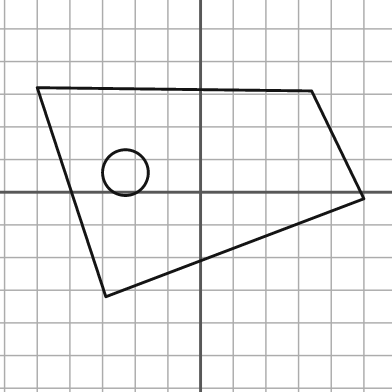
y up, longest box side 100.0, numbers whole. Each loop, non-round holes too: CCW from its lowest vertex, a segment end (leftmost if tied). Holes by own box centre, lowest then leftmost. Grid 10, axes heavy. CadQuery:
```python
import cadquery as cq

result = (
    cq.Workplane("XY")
    .moveTo(-29.0, -32.0)
    .lineTo(50.0, -2.0)
    .lineTo(34.0, 31.0)
    .lineTo(-50.0, 32.0)
    .close()
    .moveTo(-23.0, 6.0)
    .circle(7.0)
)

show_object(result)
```